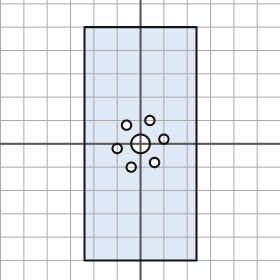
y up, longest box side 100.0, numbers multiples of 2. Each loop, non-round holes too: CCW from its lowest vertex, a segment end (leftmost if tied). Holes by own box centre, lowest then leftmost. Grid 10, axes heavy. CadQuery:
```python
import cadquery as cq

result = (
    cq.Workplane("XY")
    .moveTo(-24.0, -50.0)
    .lineTo(24.0, -50.0)
    .lineTo(24.0, 50.0)
    .lineTo(-24.0, 50.0)
    .close()
    .moveTo(-4.0, -10.0)
    .circle(2.0)
    .moveTo(6.0, -8.0)
    .circle(2.0)
    .moveTo(-10.0, -2.0)
    .circle(2.0)
    .moveTo(0.0, 0.0)
    .circle(4.0)
    .moveTo(10.0, 2.0)
    .circle(2.0)
    .moveTo(-6.0, 8.0)
    .circle(2.0)
    .moveTo(4.0, 10.0)
    .circle(2.0)
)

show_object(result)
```